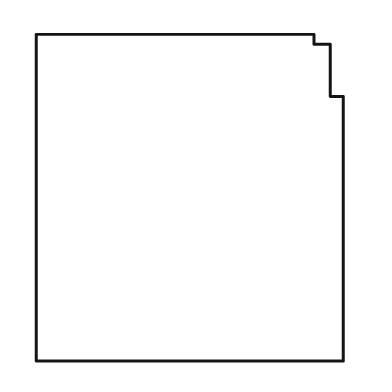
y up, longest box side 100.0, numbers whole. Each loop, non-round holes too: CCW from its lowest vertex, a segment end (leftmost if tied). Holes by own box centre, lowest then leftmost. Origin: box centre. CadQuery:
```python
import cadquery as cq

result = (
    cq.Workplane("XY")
    .moveTo(-47.0, -50.0)
    .lineTo(47.0, -50.0)
    .lineTo(47.0, 31.0)
    .lineTo(43.0, 31.0)
    .lineTo(43.0, 47.0)
    .lineTo(38.0, 47.0)
    .lineTo(38.0, 50.0)
    .lineTo(-47.0, 50.0)
    .close()
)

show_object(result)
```